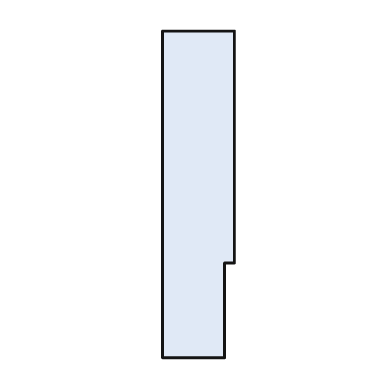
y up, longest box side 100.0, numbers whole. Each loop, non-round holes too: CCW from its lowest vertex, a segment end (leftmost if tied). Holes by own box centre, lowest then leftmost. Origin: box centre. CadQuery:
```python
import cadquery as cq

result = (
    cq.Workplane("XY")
    .moveTo(-11.0, -50.0)
    .lineTo(8.0, -50.0)
    .lineTo(8.0, -21.0)
    .lineTo(11.0, -21.0)
    .lineTo(11.0, 50.0)
    .lineTo(-11.0, 50.0)
    .close()
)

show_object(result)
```